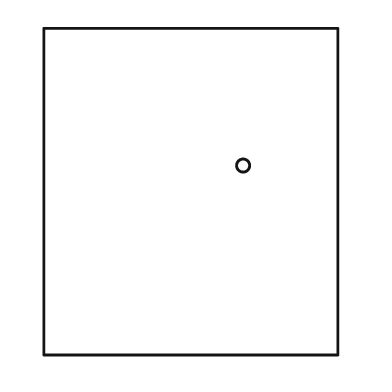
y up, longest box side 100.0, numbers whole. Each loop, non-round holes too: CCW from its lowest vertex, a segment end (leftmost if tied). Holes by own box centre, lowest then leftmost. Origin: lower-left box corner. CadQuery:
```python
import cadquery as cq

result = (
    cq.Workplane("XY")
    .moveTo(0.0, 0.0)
    .lineTo(90.0, 0.0)
    .lineTo(90.0, 100.0)
    .lineTo(0.0, 100.0)
    .close()
    .moveTo(61.0, 58.0)
    .circle(2.0)
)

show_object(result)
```